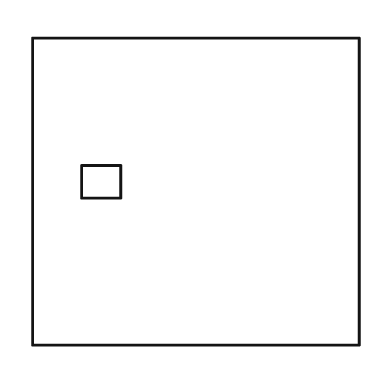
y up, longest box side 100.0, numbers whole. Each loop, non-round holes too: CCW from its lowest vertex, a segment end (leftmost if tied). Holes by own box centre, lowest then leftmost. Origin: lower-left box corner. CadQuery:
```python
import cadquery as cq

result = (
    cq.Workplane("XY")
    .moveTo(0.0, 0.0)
    .lineTo(100.0, 0.0)
    .lineTo(100.0, 94.0)
    .lineTo(0.0, 94.0)
    .close()
    .moveTo(15.0, 45.0)
    .lineTo(27.0, 45.0)
    .lineTo(27.0, 55.0)
    .lineTo(15.0, 55.0)
    .close()
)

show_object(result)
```